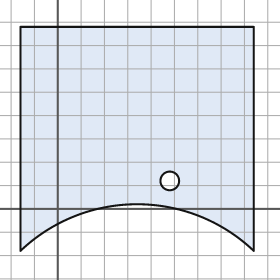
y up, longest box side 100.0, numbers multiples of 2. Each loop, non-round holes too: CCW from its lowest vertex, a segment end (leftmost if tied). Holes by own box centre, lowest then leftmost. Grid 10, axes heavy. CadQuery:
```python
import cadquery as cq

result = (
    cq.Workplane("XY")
    .moveTo(-16.0, -18.0)
    .threePointArc((34.0, 2.0), (84.0, -18.0))
    .lineTo(84.0, 78.0)
    .lineTo(-16.0, 78.0)
    .close()
    .moveTo(48.0, 12.0)
    .circle(4.0)
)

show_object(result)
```